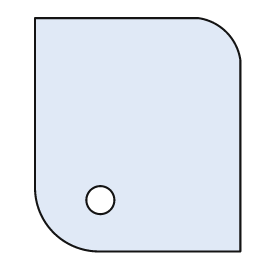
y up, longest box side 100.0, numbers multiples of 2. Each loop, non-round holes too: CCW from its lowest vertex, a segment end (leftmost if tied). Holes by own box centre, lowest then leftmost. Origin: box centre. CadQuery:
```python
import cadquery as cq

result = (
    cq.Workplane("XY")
    .moveTo(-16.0, -50.0)
    .lineTo(44.0, -50.0)
    .lineTo(44.0, 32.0)
    .threePointArc((38.0, 44.0), (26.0, 50.0))
    .lineTo(-44.0, 50.0)
    .lineTo(-44.0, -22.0)
    .threePointArc((-36.0, -42.0), (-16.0, -50.0))
    .close()
    .moveTo(-16.0, -28.0)
    .circle(6.0)
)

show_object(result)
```